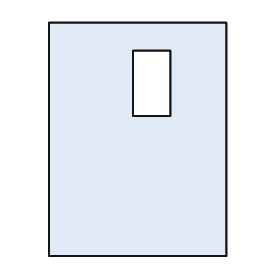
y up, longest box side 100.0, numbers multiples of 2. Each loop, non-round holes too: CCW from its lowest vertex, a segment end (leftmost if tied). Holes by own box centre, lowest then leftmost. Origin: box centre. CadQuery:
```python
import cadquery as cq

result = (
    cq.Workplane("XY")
    .moveTo(-38.0, -50.0)
    .lineTo(38.0, -50.0)
    .lineTo(38.0, 50.0)
    .lineTo(-38.0, 50.0)
    .close()
    .moveTo(-2.0, 10.0)
    .lineTo(14.0, 10.0)
    .lineTo(14.0, 38.0)
    .lineTo(-2.0, 38.0)
    .close()
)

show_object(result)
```